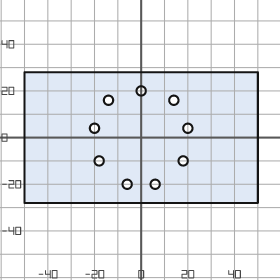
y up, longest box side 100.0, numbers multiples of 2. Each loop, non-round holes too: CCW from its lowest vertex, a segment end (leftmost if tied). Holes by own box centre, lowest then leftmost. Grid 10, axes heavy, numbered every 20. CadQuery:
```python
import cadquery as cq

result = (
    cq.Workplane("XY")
    .moveTo(-50.0, -28.0)
    .lineTo(50.0, -28.0)
    .lineTo(50.0, 28.0)
    .lineTo(-50.0, 28.0)
    .close()
    .moveTo(-6.0, -20.0)
    .circle(2.0)
    .moveTo(6.0, -20.0)
    .circle(2.0)
    .moveTo(-18.0, -10.0)
    .circle(2.0)
    .moveTo(18.0, -10.0)
    .circle(2.0)
    .moveTo(-20.0, 4.0)
    .circle(2.0)
    .moveTo(20.0, 4.0)
    .circle(2.0)
    .moveTo(-14.0, 16.0)
    .circle(2.0)
    .moveTo(14.0, 16.0)
    .circle(2.0)
    .moveTo(0.0, 20.0)
    .circle(2.0)
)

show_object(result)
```